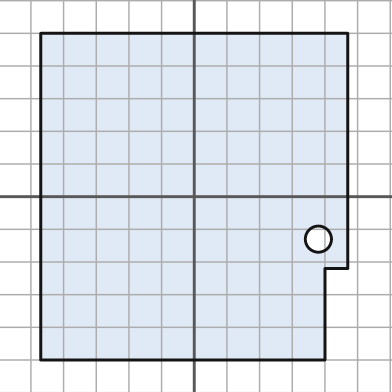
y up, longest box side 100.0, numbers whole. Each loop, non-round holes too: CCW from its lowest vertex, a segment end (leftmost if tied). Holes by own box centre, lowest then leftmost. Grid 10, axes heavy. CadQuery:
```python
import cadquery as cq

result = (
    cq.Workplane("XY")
    .moveTo(-47.0, -50.0)
    .lineTo(40.0, -50.0)
    .lineTo(40.0, -22.0)
    .lineTo(47.0, -22.0)
    .lineTo(47.0, 50.0)
    .lineTo(-47.0, 50.0)
    .close()
    .moveTo(38.0, -13.0)
    .circle(4.0)
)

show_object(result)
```